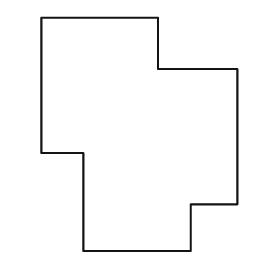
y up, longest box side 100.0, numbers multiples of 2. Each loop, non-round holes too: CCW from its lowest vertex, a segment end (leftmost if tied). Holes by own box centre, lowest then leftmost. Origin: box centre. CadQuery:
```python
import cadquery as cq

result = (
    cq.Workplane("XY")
    .moveTo(-24.0, -50.0)
    .lineTo(22.0, -50.0)
    .lineTo(22.0, -30.0)
    .lineTo(42.0, -30.0)
    .lineTo(42.0, 28.0)
    .lineTo(8.0, 28.0)
    .lineTo(8.0, 50.0)
    .lineTo(-42.0, 50.0)
    .lineTo(-42.0, -8.0)
    .lineTo(-24.0, -8.0)
    .close()
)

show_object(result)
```